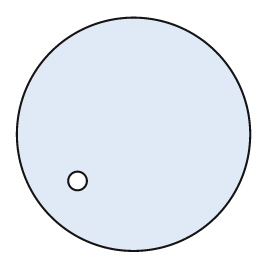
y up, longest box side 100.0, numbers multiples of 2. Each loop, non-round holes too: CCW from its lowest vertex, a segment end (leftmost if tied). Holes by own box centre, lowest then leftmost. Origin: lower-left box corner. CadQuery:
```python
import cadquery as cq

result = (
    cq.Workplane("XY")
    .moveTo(50.0, 50.0)
    .circle(50.0)
    .moveTo(26.0, 30.0)
    .circle(4.0)
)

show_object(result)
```